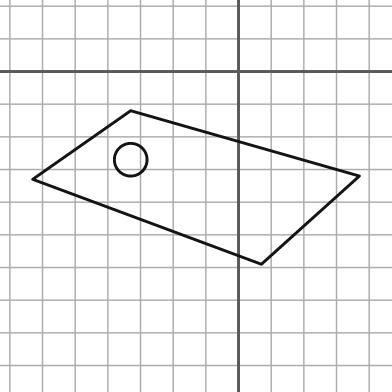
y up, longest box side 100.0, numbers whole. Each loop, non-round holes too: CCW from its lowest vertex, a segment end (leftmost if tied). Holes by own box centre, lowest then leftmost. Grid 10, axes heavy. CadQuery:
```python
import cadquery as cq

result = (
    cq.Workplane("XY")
    .moveTo(7.0, -59.0)
    .lineTo(37.0, -32.0)
    .lineTo(-33.0, -12.0)
    .lineTo(-63.0, -33.0)
    .close()
    .moveTo(-33.0, -27.0)
    .circle(5.0)
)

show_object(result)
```